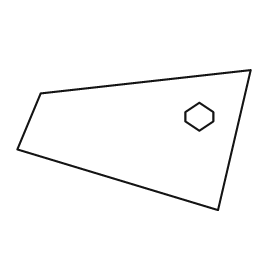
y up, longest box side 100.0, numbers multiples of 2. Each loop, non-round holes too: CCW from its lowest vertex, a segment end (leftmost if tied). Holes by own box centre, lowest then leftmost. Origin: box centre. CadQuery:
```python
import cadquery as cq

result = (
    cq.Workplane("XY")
    .moveTo(36.0, -30.0)
    .lineTo(50.0, 30.0)
    .lineTo(-40.0, 20.0)
    .lineTo(-50.0, -4.0)
    .close()
    .moveTo(28.0, 4.0)
    .lineTo(34.0, 8.0)
    .lineTo(34.0, 12.0)
    .lineTo(28.0, 16.0)
    .lineTo(22.0, 12.0)
    .lineTo(22.0, 8.0)
    .close()
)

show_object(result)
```